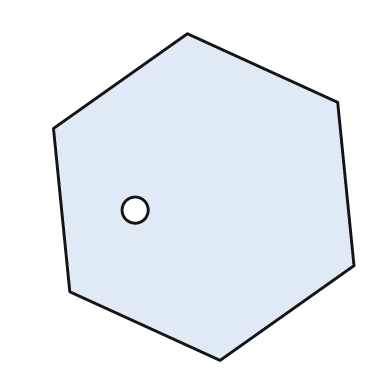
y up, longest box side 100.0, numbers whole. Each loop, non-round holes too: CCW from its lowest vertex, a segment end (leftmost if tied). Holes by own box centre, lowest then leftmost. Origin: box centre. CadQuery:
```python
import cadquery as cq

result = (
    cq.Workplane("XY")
    .moveTo(5.0, -50.0)
    .lineTo(46.0, -21.0)
    .lineTo(41.0, 29.0)
    .lineTo(-5.0, 50.0)
    .lineTo(-46.0, 21.0)
    .lineTo(-41.0, -29.0)
    .close()
    .moveTo(-21.0, -4.0)
    .circle(4.0)
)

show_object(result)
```